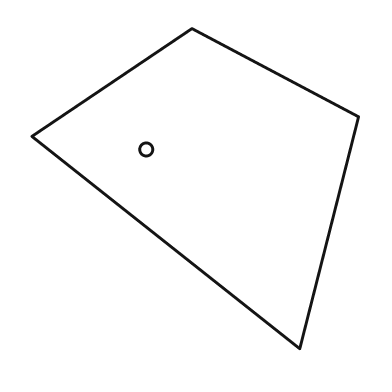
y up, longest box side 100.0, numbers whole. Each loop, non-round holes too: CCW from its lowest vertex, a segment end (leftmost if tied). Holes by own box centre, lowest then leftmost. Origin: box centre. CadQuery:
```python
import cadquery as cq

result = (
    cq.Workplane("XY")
    .moveTo(32.0, -49.0)
    .lineTo(50.0, 22.0)
    .lineTo(-1.0, 49.0)
    .lineTo(-50.0, 16.0)
    .close()
    .moveTo(-15.0, 12.0)
    .circle(2.0)
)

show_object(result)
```